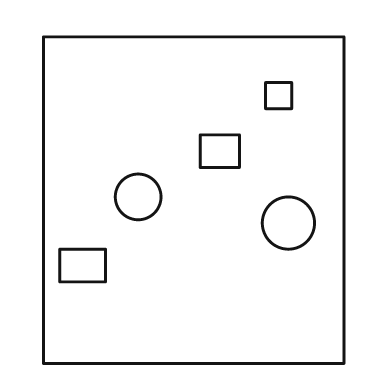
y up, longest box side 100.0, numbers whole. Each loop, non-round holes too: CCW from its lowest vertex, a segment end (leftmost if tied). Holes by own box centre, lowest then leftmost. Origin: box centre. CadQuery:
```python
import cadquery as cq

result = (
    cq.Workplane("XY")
    .moveTo(-46.0, -50.0)
    .lineTo(46.0, -50.0)
    .lineTo(46.0, 50.0)
    .lineTo(-46.0, 50.0)
    .close()
    .moveTo(-41.0, -25.0)
    .lineTo(-27.0, -25.0)
    .lineTo(-27.0, -15.0)
    .lineTo(-41.0, -15.0)
    .close()
    .moveTo(29.0, -7.0)
    .circle(8.0)
    .moveTo(-17.0, 1.0)
    .circle(7.0)
    .moveTo(2.0, 10.0)
    .lineTo(14.0, 10.0)
    .lineTo(14.0, 20.0)
    .lineTo(2.0, 20.0)
    .close()
    .moveTo(22.0, 28.0)
    .lineTo(30.0, 28.0)
    .lineTo(30.0, 36.0)
    .lineTo(22.0, 36.0)
    .close()
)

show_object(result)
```